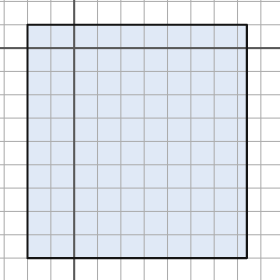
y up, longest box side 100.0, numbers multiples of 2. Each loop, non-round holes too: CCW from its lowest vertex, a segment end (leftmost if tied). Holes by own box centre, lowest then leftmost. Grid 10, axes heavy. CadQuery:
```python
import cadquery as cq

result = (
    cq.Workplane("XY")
    .moveTo(-20.0, -90.0)
    .lineTo(74.0, -90.0)
    .lineTo(74.0, 10.0)
    .lineTo(-20.0, 10.0)
    .close()
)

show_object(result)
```